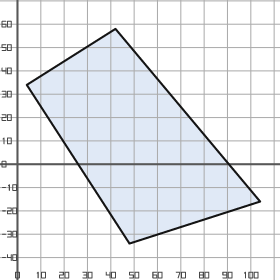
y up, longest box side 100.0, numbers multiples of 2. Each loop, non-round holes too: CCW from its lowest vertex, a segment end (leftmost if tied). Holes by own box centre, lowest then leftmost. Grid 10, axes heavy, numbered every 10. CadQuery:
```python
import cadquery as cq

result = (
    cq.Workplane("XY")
    .moveTo(48.0, -34.0)
    .lineTo(104.0, -16.0)
    .lineTo(42.0, 58.0)
    .lineTo(4.0, 34.0)
    .close()
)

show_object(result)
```